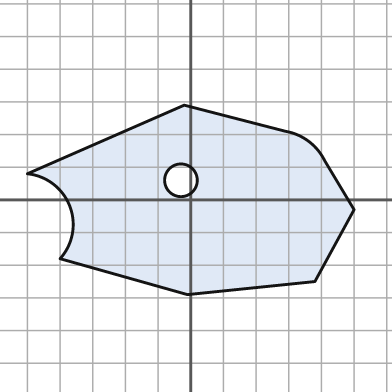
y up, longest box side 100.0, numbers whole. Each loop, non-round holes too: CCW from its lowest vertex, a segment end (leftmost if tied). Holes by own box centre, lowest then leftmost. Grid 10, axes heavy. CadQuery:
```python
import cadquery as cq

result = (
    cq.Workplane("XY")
    .moveTo(-1.0, -29.0)
    .lineTo(38.0, -25.0)
    .lineTo(50.0, -3.0)
    .lineTo(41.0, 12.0)
    .threePointArc((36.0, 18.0), (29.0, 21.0))
    .lineTo(-2.0, 29.0)
    .lineTo(-50.0, 8.0)
    .threePointArc((-37.0, -2.0), (-40.0, -18.0))
    .close()
    .moveTo(-3.0, 6.0)
    .circle(5.0)
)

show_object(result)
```